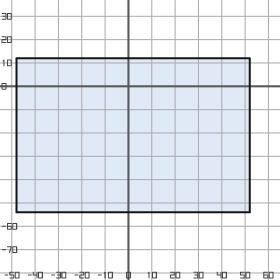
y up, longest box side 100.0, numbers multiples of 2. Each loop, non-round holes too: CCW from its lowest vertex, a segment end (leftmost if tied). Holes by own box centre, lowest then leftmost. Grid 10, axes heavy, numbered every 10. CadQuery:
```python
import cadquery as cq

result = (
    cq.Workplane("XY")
    .moveTo(-48.0, -54.0)
    .lineTo(52.0, -54.0)
    .lineTo(52.0, 12.0)
    .lineTo(-48.0, 12.0)
    .close()
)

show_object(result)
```